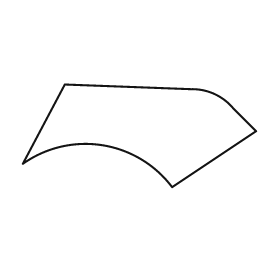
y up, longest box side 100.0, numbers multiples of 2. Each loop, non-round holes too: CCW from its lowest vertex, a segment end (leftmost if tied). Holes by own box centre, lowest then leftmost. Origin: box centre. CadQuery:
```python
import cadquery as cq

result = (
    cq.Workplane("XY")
    .moveTo(14.0, -22.0)
    .lineTo(50.0, 2.0)
    .lineTo(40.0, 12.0)
    .threePointArc((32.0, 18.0), (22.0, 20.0))
    .lineTo(-32.0, 22.0)
    .lineTo(-50.0, -12.0)
    .threePointArc((-16.0, -4.0), (14.0, -22.0))
    .close()
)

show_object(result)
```